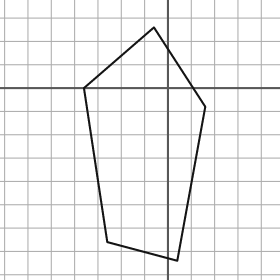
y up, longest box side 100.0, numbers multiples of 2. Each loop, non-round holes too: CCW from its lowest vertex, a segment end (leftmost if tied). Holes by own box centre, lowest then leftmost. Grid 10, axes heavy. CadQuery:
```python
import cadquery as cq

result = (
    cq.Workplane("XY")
    .moveTo(4.0, -74.0)
    .lineTo(16.0, -8.0)
    .lineTo(-6.0, 26.0)
    .lineTo(-36.0, 0.0)
    .lineTo(-26.0, -66.0)
    .close()
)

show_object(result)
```